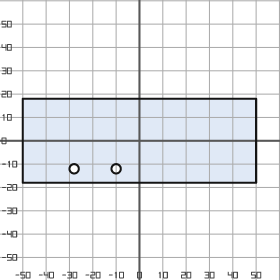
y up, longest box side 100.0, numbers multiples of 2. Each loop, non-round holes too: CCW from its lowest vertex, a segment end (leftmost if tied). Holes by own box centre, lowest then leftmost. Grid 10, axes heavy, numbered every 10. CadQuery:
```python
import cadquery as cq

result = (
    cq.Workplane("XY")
    .moveTo(-50.0, -18.0)
    .lineTo(50.0, -18.0)
    .lineTo(50.0, 18.0)
    .lineTo(-50.0, 18.0)
    .close()
    .moveTo(-28.0, -12.0)
    .circle(2.0)
    .moveTo(-10.0, -12.0)
    .circle(2.0)
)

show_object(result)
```